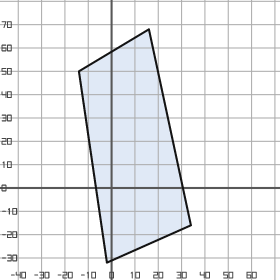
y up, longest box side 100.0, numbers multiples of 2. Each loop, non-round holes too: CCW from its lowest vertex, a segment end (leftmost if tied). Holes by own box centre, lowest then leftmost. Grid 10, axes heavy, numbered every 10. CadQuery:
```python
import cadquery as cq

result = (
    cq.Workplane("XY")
    .moveTo(-2.0, -32.0)
    .lineTo(34.0, -16.0)
    .lineTo(16.0, 68.0)
    .lineTo(-14.0, 50.0)
    .close()
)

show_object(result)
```